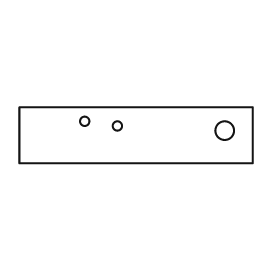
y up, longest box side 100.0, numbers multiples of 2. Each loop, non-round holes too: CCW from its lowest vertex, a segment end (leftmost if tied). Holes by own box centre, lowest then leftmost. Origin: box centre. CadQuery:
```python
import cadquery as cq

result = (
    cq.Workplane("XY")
    .moveTo(-50.0, -12.0)
    .lineTo(50.0, -12.0)
    .lineTo(50.0, 12.0)
    .lineTo(-50.0, 12.0)
    .close()
    .moveTo(38.0, 2.0)
    .circle(4.0)
    .moveTo(-8.0, 4.0)
    .circle(2.0)
    .moveTo(-22.0, 6.0)
    .circle(2.0)
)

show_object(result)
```